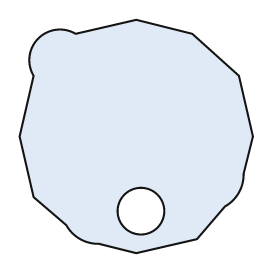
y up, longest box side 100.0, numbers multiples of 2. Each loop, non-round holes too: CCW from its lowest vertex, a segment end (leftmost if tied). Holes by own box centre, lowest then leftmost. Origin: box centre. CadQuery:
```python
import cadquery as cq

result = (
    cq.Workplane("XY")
    .moveTo(0.0, -50.0)
    .lineTo(26.0, -44.0)
    .lineTo(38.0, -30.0)
    .threePointArc((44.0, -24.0), (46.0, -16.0))
    .lineTo(50.0, 0.0)
    .lineTo(44.0, 26.0)
    .lineTo(24.0, 44.0)
    .lineTo(0.0, 50.0)
    .lineTo(-26.0, 44.0)
    .threePointArc((-42.0, 42.0), (-44.0, 26.0))
    .lineTo(-50.0, 0.0)
    .lineTo(-44.0, -26.0)
    .lineTo(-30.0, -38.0)
    .threePointArc((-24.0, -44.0), (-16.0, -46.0))
    .close()
    .moveTo(2.0, -32.0)
    .circle(10.0)
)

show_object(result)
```